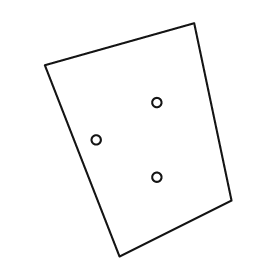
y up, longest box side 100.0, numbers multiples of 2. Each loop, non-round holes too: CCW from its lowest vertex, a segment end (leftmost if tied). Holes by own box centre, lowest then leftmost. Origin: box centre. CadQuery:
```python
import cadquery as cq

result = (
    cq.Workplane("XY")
    .moveTo(-8.0, -50.0)
    .lineTo(40.0, -26.0)
    .lineTo(24.0, 50.0)
    .lineTo(-40.0, 32.0)
    .close()
    .moveTo(8.0, -16.0)
    .circle(2.0)
    .moveTo(-18.0, 0.0)
    .circle(2.0)
    .moveTo(8.0, 16.0)
    .circle(2.0)
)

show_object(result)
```